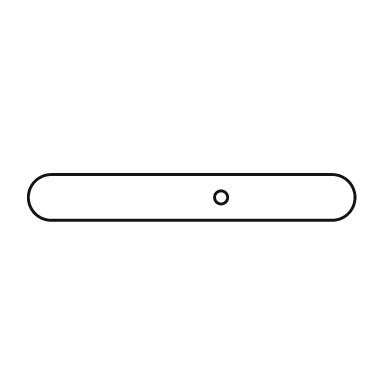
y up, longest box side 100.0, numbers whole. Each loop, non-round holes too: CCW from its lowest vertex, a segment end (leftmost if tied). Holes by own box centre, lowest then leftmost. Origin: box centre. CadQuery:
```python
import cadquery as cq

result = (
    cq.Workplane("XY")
    .moveTo(-43.0, -7.0)
    .lineTo(43.0, -7.0)
    .threePointArc((50.0, 0.0), (43.0, 7.0))
    .lineTo(-43.0, 7.0)
    .threePointArc((-50.0, 0.0), (-43.0, -7.0))
    .close()
    .moveTo(9.0, 0.0)
    .circle(2.0)
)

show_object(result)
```